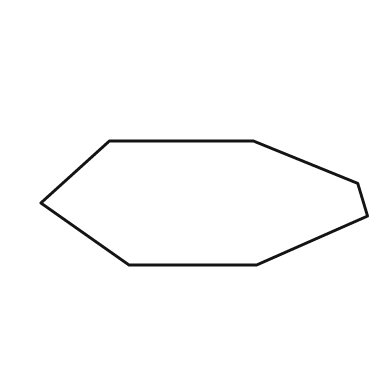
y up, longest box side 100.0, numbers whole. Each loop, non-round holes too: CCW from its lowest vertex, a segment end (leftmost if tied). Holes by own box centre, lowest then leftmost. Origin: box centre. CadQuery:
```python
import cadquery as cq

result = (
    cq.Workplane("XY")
    .moveTo(-23.0, -19.0)
    .lineTo(16.0, -19.0)
    .lineTo(50.0, -4.0)
    .lineTo(47.0, 6.0)
    .lineTo(15.0, 19.0)
    .lineTo(-29.0, 19.0)
    .lineTo(-50.0, 0.0)
    .close()
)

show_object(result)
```